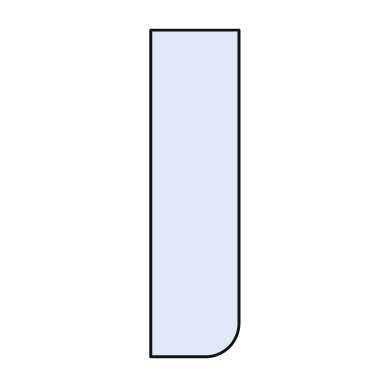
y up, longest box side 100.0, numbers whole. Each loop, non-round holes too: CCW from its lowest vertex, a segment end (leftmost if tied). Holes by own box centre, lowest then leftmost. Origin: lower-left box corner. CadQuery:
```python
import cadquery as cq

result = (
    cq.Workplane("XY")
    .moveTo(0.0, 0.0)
    .lineTo(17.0, 0.0)
    .threePointArc((24.0, 3.0), (27.0, 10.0))
    .lineTo(27.0, 100.0)
    .lineTo(0.0, 100.0)
    .close()
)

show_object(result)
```